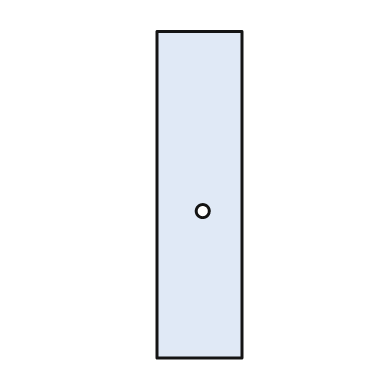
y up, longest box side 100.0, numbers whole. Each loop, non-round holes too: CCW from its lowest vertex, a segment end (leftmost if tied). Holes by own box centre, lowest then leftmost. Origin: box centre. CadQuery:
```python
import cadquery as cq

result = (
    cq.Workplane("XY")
    .moveTo(-13.0, -50.0)
    .lineTo(13.0, -50.0)
    .lineTo(13.0, 50.0)
    .lineTo(-13.0, 50.0)
    .close()
    .moveTo(1.0, -5.0)
    .circle(2.0)
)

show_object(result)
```